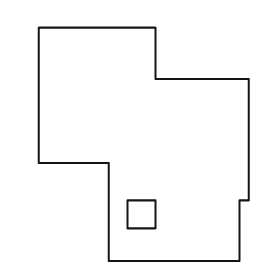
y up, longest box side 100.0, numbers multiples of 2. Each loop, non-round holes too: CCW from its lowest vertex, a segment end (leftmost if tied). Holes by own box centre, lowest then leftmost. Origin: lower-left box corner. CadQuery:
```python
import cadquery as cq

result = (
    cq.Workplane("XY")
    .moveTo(30.0, 0.0)
    .lineTo(86.0, 0.0)
    .lineTo(86.0, 26.0)
    .lineTo(90.0, 26.0)
    .lineTo(90.0, 78.0)
    .lineTo(50.0, 78.0)
    .lineTo(50.0, 100.0)
    .lineTo(0.0, 100.0)
    .lineTo(0.0, 42.0)
    .lineTo(30.0, 42.0)
    .close()
    .moveTo(38.0, 14.0)
    .lineTo(50.0, 14.0)
    .lineTo(50.0, 26.0)
    .lineTo(38.0, 26.0)
    .close()
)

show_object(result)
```